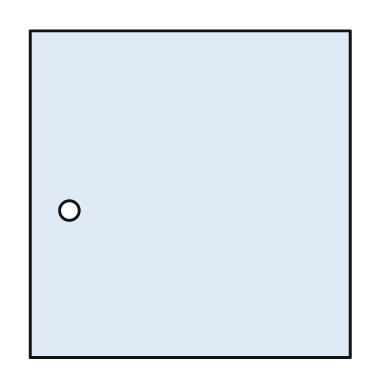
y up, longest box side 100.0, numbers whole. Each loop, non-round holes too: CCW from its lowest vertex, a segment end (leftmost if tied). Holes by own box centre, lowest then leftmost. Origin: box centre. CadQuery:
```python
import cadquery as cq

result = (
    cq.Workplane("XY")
    .moveTo(-49.0, -50.0)
    .lineTo(49.0, -50.0)
    .lineTo(49.0, 50.0)
    .lineTo(-49.0, 50.0)
    .close()
    .moveTo(-37.0, -5.0)
    .circle(3.0)
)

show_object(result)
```